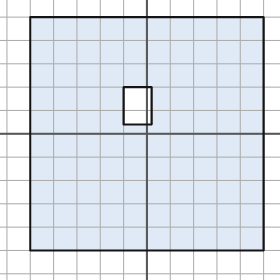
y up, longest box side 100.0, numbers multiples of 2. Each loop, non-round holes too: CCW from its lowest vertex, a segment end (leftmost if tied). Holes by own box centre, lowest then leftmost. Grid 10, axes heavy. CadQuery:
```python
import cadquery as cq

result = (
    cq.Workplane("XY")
    .moveTo(-50.0, -50.0)
    .lineTo(50.0, -50.0)
    .lineTo(50.0, 50.0)
    .lineTo(-50.0, 50.0)
    .close()
    .moveTo(-10.0, 4.0)
    .lineTo(2.0, 4.0)
    .lineTo(2.0, 20.0)
    .lineTo(-10.0, 20.0)
    .close()
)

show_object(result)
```